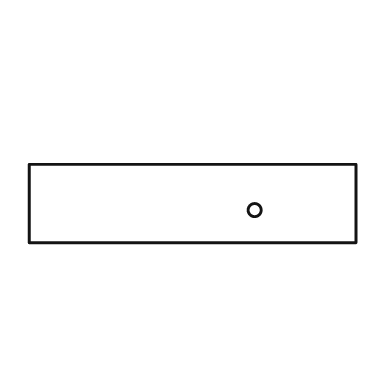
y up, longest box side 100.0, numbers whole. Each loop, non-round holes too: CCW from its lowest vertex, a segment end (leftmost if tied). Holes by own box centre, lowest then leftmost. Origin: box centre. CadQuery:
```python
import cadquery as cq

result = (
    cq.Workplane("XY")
    .moveTo(-50.0, -12.0)
    .lineTo(50.0, -12.0)
    .lineTo(50.0, 12.0)
    .lineTo(-50.0, 12.0)
    .close()
    .moveTo(19.0, -2.0)
    .circle(2.0)
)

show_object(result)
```